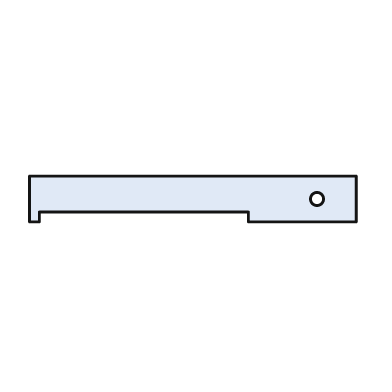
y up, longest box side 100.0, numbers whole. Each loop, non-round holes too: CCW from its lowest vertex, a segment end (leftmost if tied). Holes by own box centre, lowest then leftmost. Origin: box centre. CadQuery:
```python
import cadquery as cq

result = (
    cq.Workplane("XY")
    .moveTo(-50.0, -7.0)
    .lineTo(-47.0, -7.0)
    .lineTo(-47.0, -4.0)
    .lineTo(17.0, -4.0)
    .lineTo(17.0, -7.0)
    .lineTo(50.0, -7.0)
    .lineTo(50.0, 7.0)
    .lineTo(-50.0, 7.0)
    .close()
    .moveTo(38.0, 0.0)
    .circle(2.0)
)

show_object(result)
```